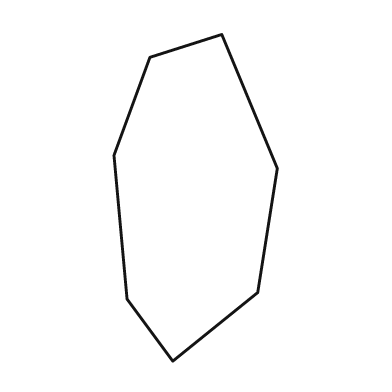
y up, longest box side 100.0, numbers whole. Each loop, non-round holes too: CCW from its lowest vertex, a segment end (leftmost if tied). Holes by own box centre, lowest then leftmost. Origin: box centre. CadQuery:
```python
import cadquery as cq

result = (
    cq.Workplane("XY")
    .moveTo(-7.0, -50.0)
    .lineTo(19.0, -29.0)
    .lineTo(25.0, 9.0)
    .lineTo(8.0, 50.0)
    .lineTo(-14.0, 43.0)
    .lineTo(-25.0, 13.0)
    .lineTo(-21.0, -31.0)
    .close()
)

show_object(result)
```